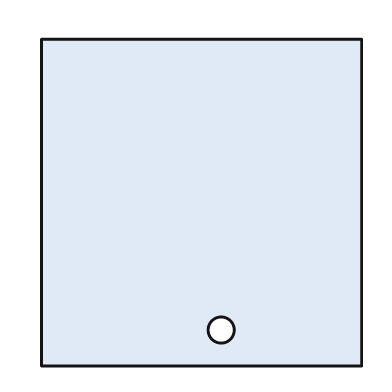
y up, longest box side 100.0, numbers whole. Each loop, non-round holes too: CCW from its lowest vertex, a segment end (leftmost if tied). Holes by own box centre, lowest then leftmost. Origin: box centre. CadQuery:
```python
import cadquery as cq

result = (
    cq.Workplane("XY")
    .moveTo(-49.0, -50.0)
    .lineTo(49.0, -50.0)
    .lineTo(49.0, 50.0)
    .lineTo(-49.0, 50.0)
    .close()
    .moveTo(6.0, -39.0)
    .circle(4.0)
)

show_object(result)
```